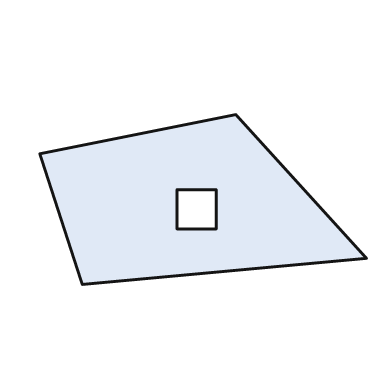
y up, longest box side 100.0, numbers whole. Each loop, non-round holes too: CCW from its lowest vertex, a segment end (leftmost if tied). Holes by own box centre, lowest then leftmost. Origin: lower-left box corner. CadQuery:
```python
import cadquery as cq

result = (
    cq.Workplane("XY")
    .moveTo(13.0, 0.0)
    .lineTo(100.0, 8.0)
    .lineTo(60.0, 52.0)
    .lineTo(0.0, 40.0)
    .close()
    .moveTo(42.0, 17.0)
    .lineTo(54.0, 17.0)
    .lineTo(54.0, 29.0)
    .lineTo(42.0, 29.0)
    .close()
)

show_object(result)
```